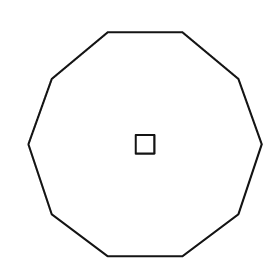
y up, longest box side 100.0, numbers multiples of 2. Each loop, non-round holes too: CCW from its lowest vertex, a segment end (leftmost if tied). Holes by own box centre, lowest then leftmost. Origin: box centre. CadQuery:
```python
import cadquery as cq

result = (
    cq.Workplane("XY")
    .moveTo(-16.0, -48.0)
    .lineTo(16.0, -48.0)
    .lineTo(40.0, -30.0)
    .lineTo(50.0, 0.0)
    .lineTo(40.0, 28.0)
    .lineTo(16.0, 48.0)
    .lineTo(-16.0, 48.0)
    .lineTo(-40.0, 28.0)
    .lineTo(-50.0, 0.0)
    .lineTo(-40.0, -30.0)
    .close()
    .moveTo(-4.0, -4.0)
    .lineTo(4.0, -4.0)
    .lineTo(4.0, 4.0)
    .lineTo(-4.0, 4.0)
    .close()
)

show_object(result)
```